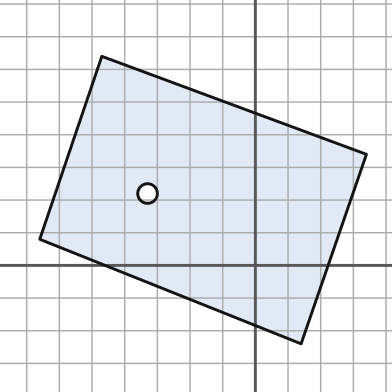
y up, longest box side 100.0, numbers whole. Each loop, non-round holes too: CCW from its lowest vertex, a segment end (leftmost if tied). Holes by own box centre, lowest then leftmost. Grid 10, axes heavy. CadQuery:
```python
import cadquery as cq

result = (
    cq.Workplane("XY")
    .moveTo(14.0, -24.0)
    .lineTo(34.0, 34.0)
    .lineTo(-47.0, 64.0)
    .lineTo(-66.0, 8.0)
    .close()
    .moveTo(-33.0, 22.0)
    .circle(3.0)
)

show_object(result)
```